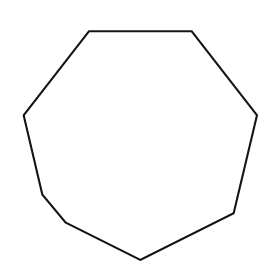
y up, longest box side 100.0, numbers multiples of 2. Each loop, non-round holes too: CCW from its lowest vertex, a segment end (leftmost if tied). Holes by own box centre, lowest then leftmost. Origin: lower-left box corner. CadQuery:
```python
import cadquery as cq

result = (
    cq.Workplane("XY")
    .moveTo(50.0, 0.0)
    .lineTo(90.0, 20.0)
    .lineTo(100.0, 62.0)
    .lineTo(72.0, 98.0)
    .lineTo(28.0, 98.0)
    .lineTo(0.0, 62.0)
    .lineTo(8.0, 28.0)
    .lineTo(18.0, 16.0)
    .close()
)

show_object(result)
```